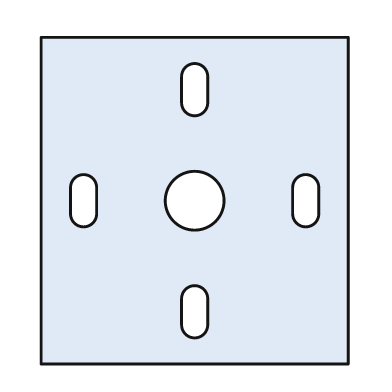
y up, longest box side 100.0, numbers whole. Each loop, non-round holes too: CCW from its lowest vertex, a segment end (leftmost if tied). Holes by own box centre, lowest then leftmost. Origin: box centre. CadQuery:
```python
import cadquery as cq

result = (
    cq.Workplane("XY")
    .moveTo(-47.0, -50.0)
    .lineTo(47.0, -50.0)
    .lineTo(47.0, 50.0)
    .lineTo(-47.0, 50.0)
    .close()
    .moveTo(-4.0, -38.0)
    .threePointArc((0.0, -42.0), (4.0, -38.0))
    .lineTo(4.0, -30.0)
    .threePointArc((0.0, -26.0), (-4.0, -30.0))
    .close()
    .moveTo(-38.0, -4.0)
    .threePointArc((-34.0, -8.0), (-30.0, -4.0))
    .lineTo(-30.0, 4.0)
    .threePointArc((-34.0, 8.0), (-38.0, 4.0))
    .close()
    .moveTo(0.0, 0.0)
    .circle(9.0)
    .moveTo(30.0, -4.0)
    .threePointArc((34.0, -8.0), (38.0, -4.0))
    .lineTo(38.0, 4.0)
    .threePointArc((34.0, 8.0), (30.0, 4.0))
    .close()
    .moveTo(-4.0, 30.0)
    .threePointArc((0.0, 26.0), (4.0, 30.0))
    .lineTo(4.0, 38.0)
    .threePointArc((0.0, 42.0), (-4.0, 38.0))
    .close()
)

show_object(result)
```